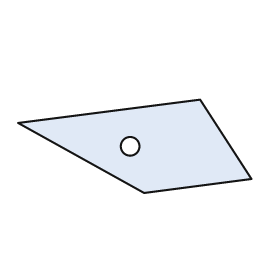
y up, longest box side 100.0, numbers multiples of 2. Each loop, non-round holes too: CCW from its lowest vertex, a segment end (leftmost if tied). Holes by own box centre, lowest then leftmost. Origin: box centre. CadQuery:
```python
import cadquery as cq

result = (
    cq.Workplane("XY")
    .moveTo(4.0, -20.0)
    .lineTo(50.0, -14.0)
    .lineTo(28.0, 20.0)
    .lineTo(-50.0, 10.0)
    .close()
    .moveTo(-2.0, 0.0)
    .circle(4.0)
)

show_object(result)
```